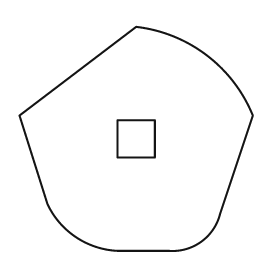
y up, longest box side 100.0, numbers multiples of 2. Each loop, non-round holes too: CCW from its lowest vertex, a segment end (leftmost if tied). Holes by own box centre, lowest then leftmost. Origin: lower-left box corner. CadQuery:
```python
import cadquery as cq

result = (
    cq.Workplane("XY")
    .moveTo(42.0, 0.0)
    .lineTo(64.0, 0.0)
    .threePointArc((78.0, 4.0), (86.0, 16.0))
    .lineTo(100.0, 58.0)
    .threePointArc((80.0, 84.0), (50.0, 96.0))
    .lineTo(0.0, 58.0)
    .lineTo(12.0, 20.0)
    .threePointArc((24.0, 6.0), (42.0, 0.0))
    .close()
    .moveTo(42.0, 40.0)
    .lineTo(58.0, 40.0)
    .lineTo(58.0, 56.0)
    .lineTo(42.0, 56.0)
    .close()
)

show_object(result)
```